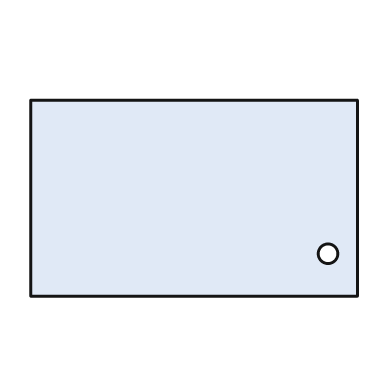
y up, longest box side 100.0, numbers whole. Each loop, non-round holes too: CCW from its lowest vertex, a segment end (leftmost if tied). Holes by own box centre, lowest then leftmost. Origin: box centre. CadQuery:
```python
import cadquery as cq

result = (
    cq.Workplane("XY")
    .moveTo(-50.0, -30.0)
    .lineTo(50.0, -30.0)
    .lineTo(50.0, 30.0)
    .lineTo(-50.0, 30.0)
    .close()
    .moveTo(41.0, -17.0)
    .circle(3.0)
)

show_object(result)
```